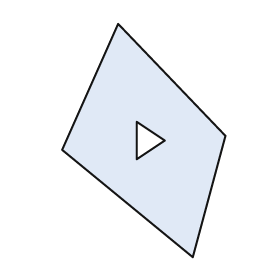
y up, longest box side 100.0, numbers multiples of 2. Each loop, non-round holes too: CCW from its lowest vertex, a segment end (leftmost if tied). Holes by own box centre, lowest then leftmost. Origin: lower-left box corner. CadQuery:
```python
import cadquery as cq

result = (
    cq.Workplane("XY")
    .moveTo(56.0, 0.0)
    .lineTo(70.0, 52.0)
    .lineTo(24.0, 100.0)
    .lineTo(0.0, 46.0)
    .close()
    .moveTo(32.0, 42.0)
    .lineTo(44.0, 50.0)
    .lineTo(32.0, 58.0)
    .close()
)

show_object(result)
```